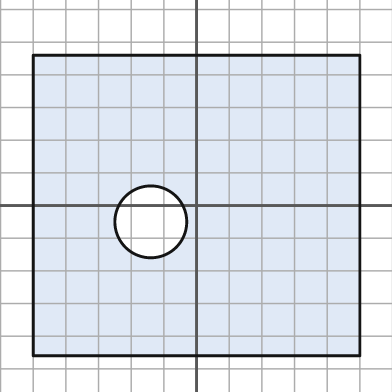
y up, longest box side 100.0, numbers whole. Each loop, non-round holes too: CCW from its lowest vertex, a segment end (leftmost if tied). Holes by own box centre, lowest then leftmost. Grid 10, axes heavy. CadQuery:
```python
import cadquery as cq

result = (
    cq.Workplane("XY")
    .moveTo(-50.0, -46.0)
    .lineTo(50.0, -46.0)
    .lineTo(50.0, 46.0)
    .lineTo(-50.0, 46.0)
    .close()
    .moveTo(-14.0, -5.0)
    .circle(11.0)
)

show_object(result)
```